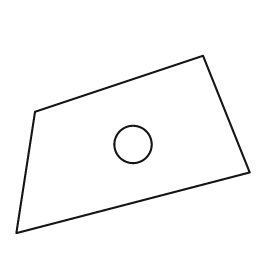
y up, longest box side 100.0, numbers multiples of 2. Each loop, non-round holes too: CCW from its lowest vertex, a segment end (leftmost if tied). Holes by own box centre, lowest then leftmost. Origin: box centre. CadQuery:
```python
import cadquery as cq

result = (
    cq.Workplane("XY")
    .moveTo(-50.0, -38.0)
    .lineTo(50.0, -12.0)
    .lineTo(30.0, 38.0)
    .lineTo(-42.0, 14.0)
    .close()
    .moveTo(0.0, 0.0)
    .circle(8.0)
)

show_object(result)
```